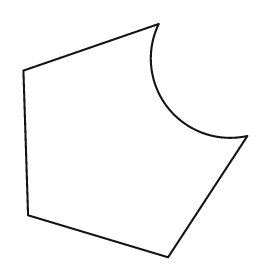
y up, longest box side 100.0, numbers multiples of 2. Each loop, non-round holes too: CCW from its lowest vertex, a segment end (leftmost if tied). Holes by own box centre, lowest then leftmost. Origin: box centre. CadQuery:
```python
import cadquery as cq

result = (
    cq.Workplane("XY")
    .moveTo(14.0, -50.0)
    .lineTo(48.0, 2.0)
    .threePointArc((14.0, 14.0), (10.0, 50.0))
    .lineTo(-48.0, 30.0)
    .lineTo(-46.0, -32.0)
    .close()
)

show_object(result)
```